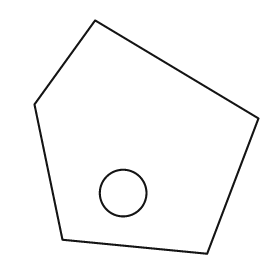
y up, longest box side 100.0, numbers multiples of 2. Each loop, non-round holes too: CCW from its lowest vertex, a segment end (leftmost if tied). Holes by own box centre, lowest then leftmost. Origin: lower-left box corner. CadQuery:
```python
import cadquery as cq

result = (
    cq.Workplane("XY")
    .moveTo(74.0, 0.0)
    .lineTo(96.0, 58.0)
    .lineTo(26.0, 100.0)
    .lineTo(0.0, 64.0)
    .lineTo(12.0, 6.0)
    .close()
    .moveTo(38.0, 26.0)
    .circle(10.0)
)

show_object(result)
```